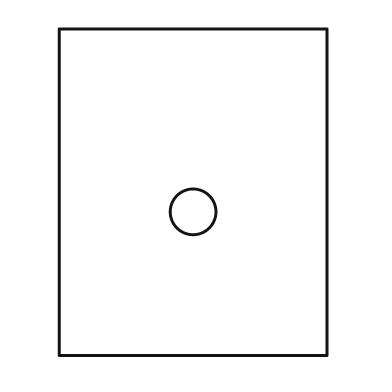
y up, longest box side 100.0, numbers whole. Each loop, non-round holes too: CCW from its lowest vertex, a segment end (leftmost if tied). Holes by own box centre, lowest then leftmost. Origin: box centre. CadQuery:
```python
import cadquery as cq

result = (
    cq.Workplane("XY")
    .moveTo(-41.0, -50.0)
    .lineTo(41.0, -50.0)
    .lineTo(41.0, 50.0)
    .lineTo(-41.0, 50.0)
    .close()
    .moveTo(0.0, -6.0)
    .circle(7.0)
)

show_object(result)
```